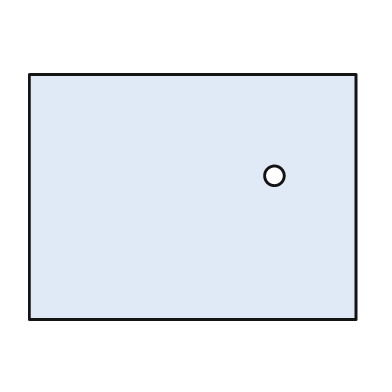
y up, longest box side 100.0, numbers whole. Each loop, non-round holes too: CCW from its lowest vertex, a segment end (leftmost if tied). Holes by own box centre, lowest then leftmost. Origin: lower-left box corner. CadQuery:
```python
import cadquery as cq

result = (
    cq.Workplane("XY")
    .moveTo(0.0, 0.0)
    .lineTo(100.0, 0.0)
    .lineTo(100.0, 75.0)
    .lineTo(0.0, 75.0)
    .close()
    .moveTo(75.0, 44.0)
    .circle(3.0)
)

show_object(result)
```